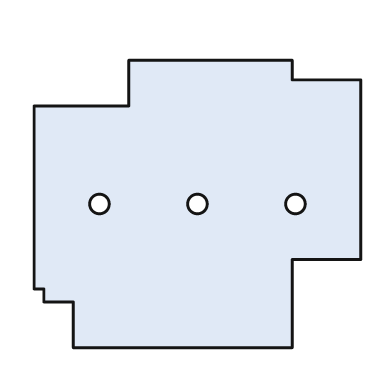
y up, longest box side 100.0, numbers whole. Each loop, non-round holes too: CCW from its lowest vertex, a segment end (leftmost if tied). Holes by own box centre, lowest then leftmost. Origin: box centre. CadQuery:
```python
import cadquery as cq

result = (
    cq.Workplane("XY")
    .moveTo(-38.0, -44.0)
    .lineTo(29.0, -44.0)
    .lineTo(29.0, -17.0)
    .lineTo(50.0, -17.0)
    .lineTo(50.0, 38.0)
    .lineTo(29.0, 38.0)
    .lineTo(29.0, 44.0)
    .lineTo(-21.0, 44.0)
    .lineTo(-21.0, 30.0)
    .lineTo(-50.0, 30.0)
    .lineTo(-50.0, -26.0)
    .lineTo(-47.0, -26.0)
    .lineTo(-47.0, -30.0)
    .lineTo(-38.0, -30.0)
    .close()
    .moveTo(-30.0, 0.0)
    .circle(3.0)
    .moveTo(0.0, 0.0)
    .circle(3.0)
    .moveTo(30.0, 0.0)
    .circle(3.0)
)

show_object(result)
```